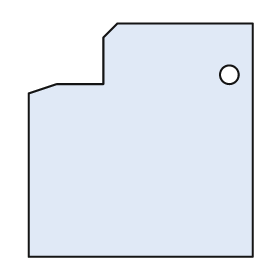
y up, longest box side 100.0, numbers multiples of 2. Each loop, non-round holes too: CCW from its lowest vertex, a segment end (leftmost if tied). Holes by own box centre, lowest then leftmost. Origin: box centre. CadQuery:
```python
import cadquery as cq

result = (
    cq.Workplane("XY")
    .moveTo(-48.0, -50.0)
    .lineTo(48.0, -50.0)
    .lineTo(48.0, 50.0)
    .lineTo(-10.0, 50.0)
    .lineTo(-16.0, 44.0)
    .lineTo(-16.0, 24.0)
    .lineTo(-36.0, 24.0)
    .lineTo(-48.0, 20.0)
    .close()
    .moveTo(38.0, 28.0)
    .circle(4.0)
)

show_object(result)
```